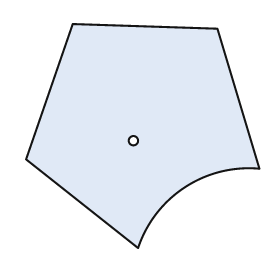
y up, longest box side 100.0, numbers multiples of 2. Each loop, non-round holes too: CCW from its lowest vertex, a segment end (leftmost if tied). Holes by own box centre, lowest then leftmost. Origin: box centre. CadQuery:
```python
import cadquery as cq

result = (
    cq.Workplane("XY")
    .moveTo(-2.0, -48.0)
    .threePointArc((18.0, -22.0), (50.0, -14.0))
    .lineTo(32.0, 46.0)
    .lineTo(-30.0, 48.0)
    .lineTo(-50.0, -10.0)
    .close()
    .moveTo(-4.0, -2.0)
    .circle(2.0)
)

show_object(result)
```